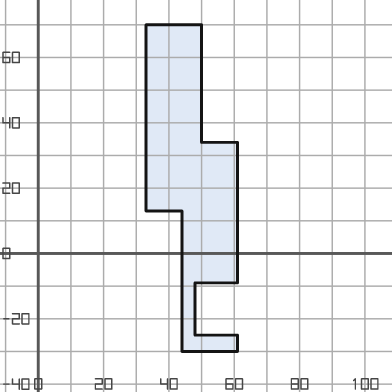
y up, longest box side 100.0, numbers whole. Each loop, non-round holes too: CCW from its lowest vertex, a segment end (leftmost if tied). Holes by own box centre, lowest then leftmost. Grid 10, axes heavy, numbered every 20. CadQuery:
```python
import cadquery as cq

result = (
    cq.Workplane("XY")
    .moveTo(44.0, -30.0)
    .lineTo(61.0, -30.0)
    .lineTo(61.0, -25.0)
    .lineTo(48.0, -25.0)
    .lineTo(48.0, -9.0)
    .lineTo(61.0, -9.0)
    .lineTo(61.0, 34.0)
    .lineTo(50.0, 34.0)
    .lineTo(50.0, 70.0)
    .lineTo(33.0, 70.0)
    .lineTo(33.0, 13.0)
    .lineTo(44.0, 13.0)
    .close()
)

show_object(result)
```